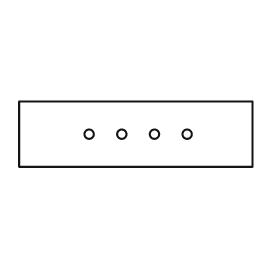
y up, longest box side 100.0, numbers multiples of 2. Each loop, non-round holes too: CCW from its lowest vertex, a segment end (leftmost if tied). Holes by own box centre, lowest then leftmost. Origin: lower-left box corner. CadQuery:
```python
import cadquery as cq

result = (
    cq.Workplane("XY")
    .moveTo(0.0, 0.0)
    .lineTo(100.0, 0.0)
    .lineTo(100.0, 28.0)
    .lineTo(0.0, 28.0)
    .close()
    .moveTo(30.0, 14.0)
    .circle(2.0)
    .moveTo(44.0, 14.0)
    .circle(2.0)
    .moveTo(58.0, 14.0)
    .circle(2.0)
    .moveTo(72.0, 14.0)
    .circle(2.0)
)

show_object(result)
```